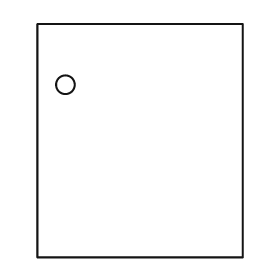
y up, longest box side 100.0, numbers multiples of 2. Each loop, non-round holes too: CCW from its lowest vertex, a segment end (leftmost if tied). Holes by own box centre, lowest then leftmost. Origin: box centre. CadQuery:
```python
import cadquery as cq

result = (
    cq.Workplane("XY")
    .moveTo(-44.0, -50.0)
    .lineTo(44.0, -50.0)
    .lineTo(44.0, 50.0)
    .lineTo(-44.0, 50.0)
    .close()
    .moveTo(-32.0, 24.0)
    .circle(4.0)
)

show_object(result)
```